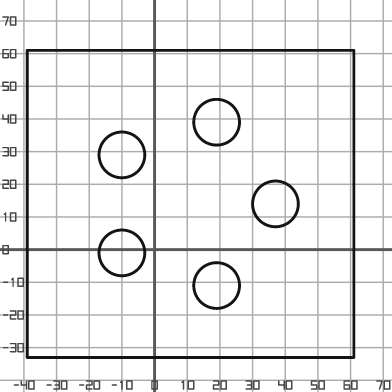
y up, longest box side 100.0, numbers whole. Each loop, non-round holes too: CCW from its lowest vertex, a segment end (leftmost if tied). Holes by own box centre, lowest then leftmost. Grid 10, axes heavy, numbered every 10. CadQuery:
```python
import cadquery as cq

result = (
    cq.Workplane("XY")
    .moveTo(-39.0, -33.0)
    .lineTo(61.0, -33.0)
    .lineTo(61.0, 61.0)
    .lineTo(-39.0, 61.0)
    .close()
    .moveTo(19.0, -11.0)
    .circle(7.0)
    .moveTo(-10.0, -1.0)
    .circle(7.0)
    .moveTo(37.0, 14.0)
    .circle(7.0)
    .moveTo(-10.0, 29.0)
    .circle(7.0)
    .moveTo(19.0, 39.0)
    .circle(7.0)
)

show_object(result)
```